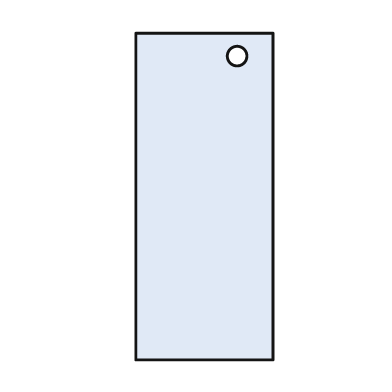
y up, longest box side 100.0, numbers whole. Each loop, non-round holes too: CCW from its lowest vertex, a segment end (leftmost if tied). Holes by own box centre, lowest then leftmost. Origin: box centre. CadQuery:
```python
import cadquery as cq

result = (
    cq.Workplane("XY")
    .moveTo(-21.0, -50.0)
    .lineTo(21.0, -50.0)
    .lineTo(21.0, 50.0)
    .lineTo(-21.0, 50.0)
    .close()
    .moveTo(10.0, 43.0)
    .circle(3.0)
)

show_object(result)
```